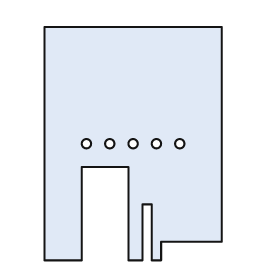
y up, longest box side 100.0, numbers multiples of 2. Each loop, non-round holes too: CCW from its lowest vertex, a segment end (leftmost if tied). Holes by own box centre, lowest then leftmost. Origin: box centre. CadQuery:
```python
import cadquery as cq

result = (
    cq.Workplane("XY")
    .moveTo(-38.0, -50.0)
    .lineTo(-22.0, -50.0)
    .lineTo(-22.0, -10.0)
    .lineTo(-2.0, -10.0)
    .lineTo(-2.0, -50.0)
    .lineTo(4.0, -50.0)
    .lineTo(4.0, -26.0)
    .lineTo(8.0, -26.0)
    .lineTo(8.0, -50.0)
    .lineTo(12.0, -50.0)
    .lineTo(12.0, -42.0)
    .lineTo(38.0, -42.0)
    .lineTo(38.0, 50.0)
    .lineTo(-38.0, 50.0)
    .close()
    .moveTo(-20.0, 0.0)
    .circle(2.0)
    .moveTo(-10.0, 0.0)
    .circle(2.0)
    .moveTo(0.0, 0.0)
    .circle(2.0)
    .moveTo(10.0, 0.0)
    .circle(2.0)
    .moveTo(20.0, 0.0)
    .circle(2.0)
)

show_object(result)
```